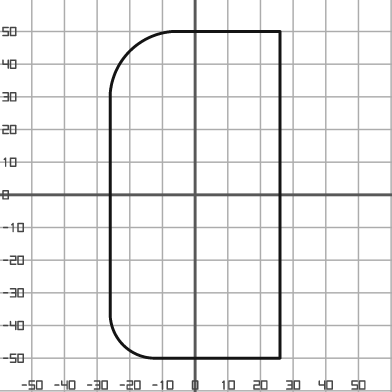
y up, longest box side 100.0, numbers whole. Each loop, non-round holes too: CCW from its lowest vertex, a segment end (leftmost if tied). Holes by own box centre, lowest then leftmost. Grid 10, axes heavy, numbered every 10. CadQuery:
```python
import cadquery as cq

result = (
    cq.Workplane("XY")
    .moveTo(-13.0, -50.0)
    .lineTo(26.0, -50.0)
    .lineTo(26.0, 50.0)
    .lineTo(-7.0, 50.0)
    .threePointArc((-20.0, 44.0), (-26.0, 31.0))
    .lineTo(-26.0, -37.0)
    .threePointArc((-22.0, -46.0), (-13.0, -50.0))
    .close()
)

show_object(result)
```